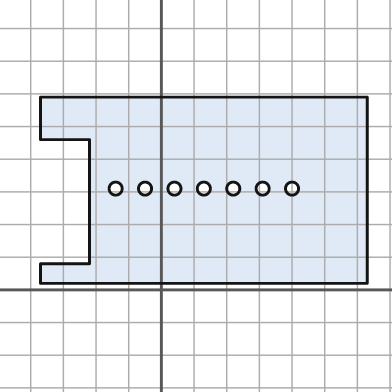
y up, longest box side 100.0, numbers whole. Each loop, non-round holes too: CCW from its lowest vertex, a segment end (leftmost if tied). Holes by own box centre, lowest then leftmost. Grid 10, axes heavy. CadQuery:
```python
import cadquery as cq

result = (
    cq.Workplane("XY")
    .moveTo(-37.0, 2.0)
    .lineTo(63.0, 2.0)
    .lineTo(63.0, 59.0)
    .lineTo(-37.0, 59.0)
    .lineTo(-37.0, 46.0)
    .lineTo(-22.0, 46.0)
    .lineTo(-22.0, 8.0)
    .lineTo(-37.0, 8.0)
    .close()
    .moveTo(-14.0, 31.0)
    .circle(2.0)
    .moveTo(-5.0, 31.0)
    .circle(2.0)
    .moveTo(4.0, 31.0)
    .circle(2.0)
    .moveTo(13.0, 31.0)
    .circle(2.0)
    .moveTo(22.0, 31.0)
    .circle(2.0)
    .moveTo(31.0, 31.0)
    .circle(2.0)
    .moveTo(40.0, 31.0)
    .circle(2.0)
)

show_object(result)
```